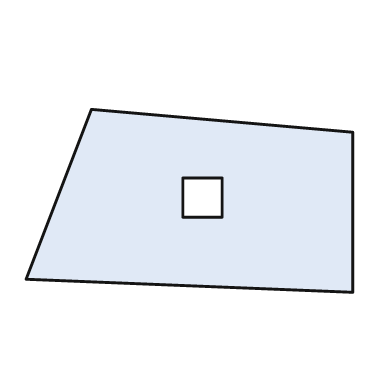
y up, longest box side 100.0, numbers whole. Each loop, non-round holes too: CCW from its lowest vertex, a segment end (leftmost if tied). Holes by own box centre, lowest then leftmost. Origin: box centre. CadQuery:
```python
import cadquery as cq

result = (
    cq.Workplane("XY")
    .moveTo(50.0, -28.0)
    .lineTo(50.0, 21.0)
    .lineTo(-30.0, 28.0)
    .lineTo(-50.0, -24.0)
    .close()
    .moveTo(-2.0, -5.0)
    .lineTo(10.0, -5.0)
    .lineTo(10.0, 7.0)
    .lineTo(-2.0, 7.0)
    .close()
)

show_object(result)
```